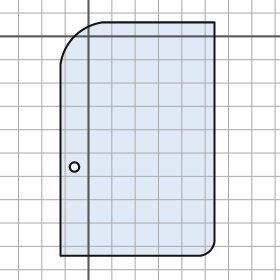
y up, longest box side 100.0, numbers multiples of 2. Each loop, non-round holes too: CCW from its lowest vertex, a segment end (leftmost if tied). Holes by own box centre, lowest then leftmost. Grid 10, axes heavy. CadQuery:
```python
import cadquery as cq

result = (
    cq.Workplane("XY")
    .moveTo(-12.0, -94.0)
    .lineTo(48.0, -94.0)
    .threePointArc((52.0, -92.0), (54.0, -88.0))
    .lineTo(54.0, 6.0)
    .lineTo(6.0, 6.0)
    .threePointArc((-6.0, 0.0), (-12.0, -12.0))
    .close()
    .moveTo(-6.0, -56.0)
    .circle(2.0)
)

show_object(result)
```